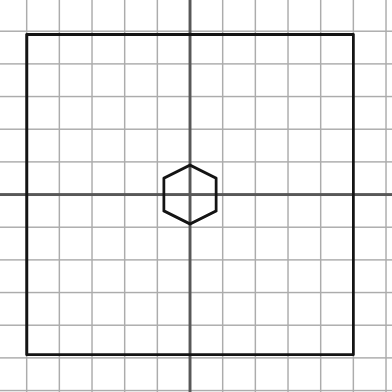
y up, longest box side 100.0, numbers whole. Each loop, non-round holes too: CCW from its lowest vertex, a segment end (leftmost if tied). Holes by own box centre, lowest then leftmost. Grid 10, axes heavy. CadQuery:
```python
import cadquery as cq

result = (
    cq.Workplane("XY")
    .moveTo(-50.0, -49.0)
    .lineTo(50.0, -49.0)
    .lineTo(50.0, 49.0)
    .lineTo(-50.0, 49.0)
    .close()
    .moveTo(0.0, -9.0)
    .lineTo(8.0, -5.0)
    .lineTo(8.0, 5.0)
    .lineTo(0.0, 9.0)
    .lineTo(-8.0, 5.0)
    .lineTo(-8.0, -5.0)
    .close()
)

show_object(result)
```